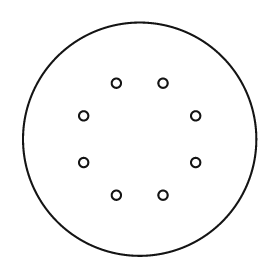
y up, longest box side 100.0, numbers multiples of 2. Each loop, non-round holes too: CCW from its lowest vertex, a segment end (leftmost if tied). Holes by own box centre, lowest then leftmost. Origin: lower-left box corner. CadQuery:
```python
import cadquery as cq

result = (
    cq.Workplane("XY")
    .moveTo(50.0, 50.0)
    .circle(50.0)
    .moveTo(40.0, 26.0)
    .circle(2.0)
    .moveTo(60.0, 26.0)
    .circle(2.0)
    .moveTo(26.0, 40.0)
    .circle(2.0)
    .moveTo(74.0, 40.0)
    .circle(2.0)
    .moveTo(26.0, 60.0)
    .circle(2.0)
    .moveTo(74.0, 60.0)
    .circle(2.0)
    .moveTo(40.0, 74.0)
    .circle(2.0)
    .moveTo(60.0, 74.0)
    .circle(2.0)
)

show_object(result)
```